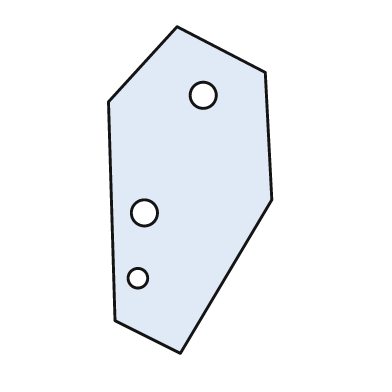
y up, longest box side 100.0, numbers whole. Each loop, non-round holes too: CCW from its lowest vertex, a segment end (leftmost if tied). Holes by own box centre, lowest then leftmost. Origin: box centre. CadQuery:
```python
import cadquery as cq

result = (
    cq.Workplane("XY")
    .moveTo(-3.0, -50.0)
    .lineTo(25.0, -3.0)
    .lineTo(23.0, 36.0)
    .lineTo(-4.0, 50.0)
    .lineTo(-25.0, 27.0)
    .lineTo(-23.0, -40.0)
    .close()
    .moveTo(-16.0, -27.0)
    .circle(3.0)
    .moveTo(-14.0, -7.0)
    .circle(4.0)
    .moveTo(4.0, 29.0)
    .circle(4.0)
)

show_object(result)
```